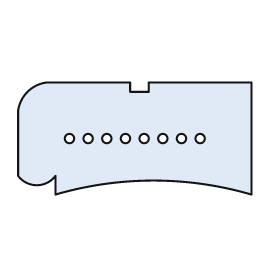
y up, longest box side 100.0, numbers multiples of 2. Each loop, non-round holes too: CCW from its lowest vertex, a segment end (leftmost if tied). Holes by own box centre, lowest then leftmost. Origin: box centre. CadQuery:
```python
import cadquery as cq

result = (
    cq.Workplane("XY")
    .moveTo(-34.0, -24.0)
    .threePointArc((8.0, -18.0), (50.0, -24.0))
    .lineTo(50.0, 24.0)
    .lineTo(6.0, 24.0)
    .lineTo(6.0, 20.0)
    .lineTo(-2.0, 20.0)
    .lineTo(-2.0, 24.0)
    .lineTo(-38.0, 24.0)
    .threePointArc((-46.0, 20.0), (-50.0, 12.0))
    .lineTo(-50.0, -16.0)
    .threePointArc((-42.0, -20.0), (-34.0, -16.0))
    .close()
    .moveTo(-28.0, 0.0)
    .circle(2.0)
    .moveTo(-20.0, 0.0)
    .circle(2.0)
    .moveTo(-12.0, 0.0)
    .circle(2.0)
    .moveTo(-4.0, 0.0)
    .circle(2.0)
    .moveTo(4.0, 0.0)
    .circle(2.0)
    .moveTo(12.0, 0.0)
    .circle(2.0)
    .moveTo(20.0, 0.0)
    .circle(2.0)
    .moveTo(28.0, 0.0)
    .circle(2.0)
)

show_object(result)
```